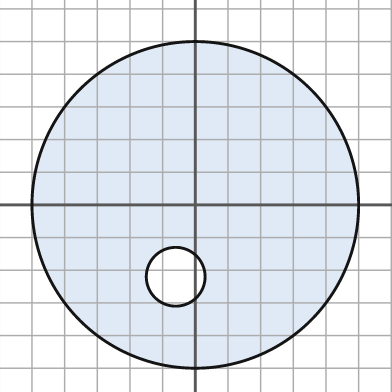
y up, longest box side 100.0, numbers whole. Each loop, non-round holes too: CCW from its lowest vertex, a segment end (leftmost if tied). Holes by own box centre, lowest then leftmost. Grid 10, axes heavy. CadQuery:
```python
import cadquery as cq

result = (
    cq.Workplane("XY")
    .moveTo(0.0, 0.0)
    .circle(50.0)
    .moveTo(-6.0, -22.0)
    .circle(9.0)
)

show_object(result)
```